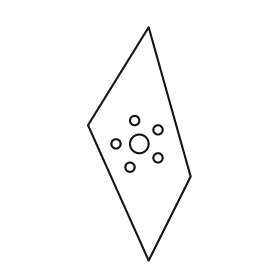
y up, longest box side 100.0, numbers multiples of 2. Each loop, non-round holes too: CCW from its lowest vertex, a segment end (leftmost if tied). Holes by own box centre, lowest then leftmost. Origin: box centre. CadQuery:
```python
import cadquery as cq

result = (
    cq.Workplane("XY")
    .moveTo(4.0, -50.0)
    .lineTo(22.0, -14.0)
    .lineTo(4.0, 50.0)
    .lineTo(-22.0, 8.0)
    .close()
    .moveTo(-4.0, -10.0)
    .circle(2.0)
    .moveTo(8.0, -6.0)
    .circle(2.0)
    .moveTo(-10.0, 0.0)
    .circle(2.0)
    .moveTo(0.0, 0.0)
    .circle(4.0)
    .moveTo(8.0, 6.0)
    .circle(2.0)
    .moveTo(-2.0, 10.0)
    .circle(2.0)
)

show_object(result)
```